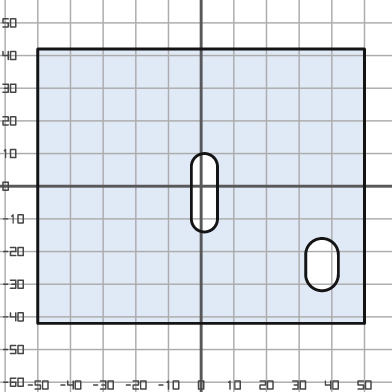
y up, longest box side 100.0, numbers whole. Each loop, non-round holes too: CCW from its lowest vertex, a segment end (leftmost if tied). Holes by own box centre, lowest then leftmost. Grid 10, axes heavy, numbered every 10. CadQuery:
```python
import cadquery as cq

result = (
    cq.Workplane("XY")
    .moveTo(-50.0, -42.0)
    .lineTo(50.0, -42.0)
    .lineTo(50.0, 42.0)
    .lineTo(-50.0, 42.0)
    .close()
    .moveTo(32.0, -27.0)
    .threePointArc((37.0, -32.0), (42.0, -27.0))
    .lineTo(42.0, -21.0)
    .threePointArc((37.0, -16.0), (32.0, -21.0))
    .close()
    .moveTo(-3.0, -10.0)
    .threePointArc((1.0, -14.0), (5.0, -10.0))
    .lineTo(5.0, 6.0)
    .threePointArc((1.0, 10.0), (-3.0, 6.0))
    .close()
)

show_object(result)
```